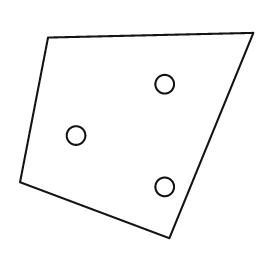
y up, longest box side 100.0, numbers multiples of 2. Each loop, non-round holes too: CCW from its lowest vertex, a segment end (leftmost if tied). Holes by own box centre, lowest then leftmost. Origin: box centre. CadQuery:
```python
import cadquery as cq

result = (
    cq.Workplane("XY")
    .moveTo(14.0, -44.0)
    .lineTo(50.0, 44.0)
    .lineTo(-38.0, 42.0)
    .lineTo(-50.0, -20.0)
    .close()
    .moveTo(12.0, -22.0)
    .circle(4.0)
    .moveTo(-26.0, 0.0)
    .circle(4.0)
    .moveTo(12.0, 22.0)
    .circle(4.0)
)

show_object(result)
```